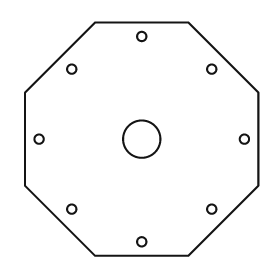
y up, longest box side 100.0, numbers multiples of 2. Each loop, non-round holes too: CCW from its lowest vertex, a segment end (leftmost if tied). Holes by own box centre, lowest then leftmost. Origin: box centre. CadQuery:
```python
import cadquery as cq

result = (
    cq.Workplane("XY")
    .moveTo(-20.0, -50.0)
    .lineTo(20.0, -50.0)
    .lineTo(50.0, -20.0)
    .lineTo(50.0, 20.0)
    .lineTo(20.0, 50.0)
    .lineTo(-20.0, 50.0)
    .lineTo(-50.0, 20.0)
    .lineTo(-50.0, -20.0)
    .close()
    .moveTo(0.0, -44.0)
    .circle(2.0)
    .moveTo(-30.0, -30.0)
    .circle(2.0)
    .moveTo(30.0, -30.0)
    .circle(2.0)
    .moveTo(-44.0, 0.0)
    .circle(2.0)
    .moveTo(0.0, 0.0)
    .circle(8.0)
    .moveTo(44.0, 0.0)
    .circle(2.0)
    .moveTo(-30.0, 30.0)
    .circle(2.0)
    .moveTo(30.0, 30.0)
    .circle(2.0)
    .moveTo(0.0, 44.0)
    .circle(2.0)
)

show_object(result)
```